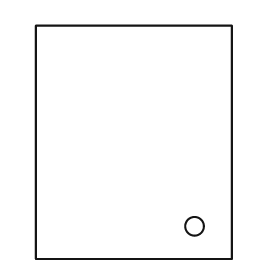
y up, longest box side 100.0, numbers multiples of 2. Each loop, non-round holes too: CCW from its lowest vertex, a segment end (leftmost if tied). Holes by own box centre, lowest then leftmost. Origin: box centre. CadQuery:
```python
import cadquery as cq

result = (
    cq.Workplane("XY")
    .moveTo(-42.0, -50.0)
    .lineTo(42.0, -50.0)
    .lineTo(42.0, 50.0)
    .lineTo(-42.0, 50.0)
    .close()
    .moveTo(26.0, -36.0)
    .circle(4.0)
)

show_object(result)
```